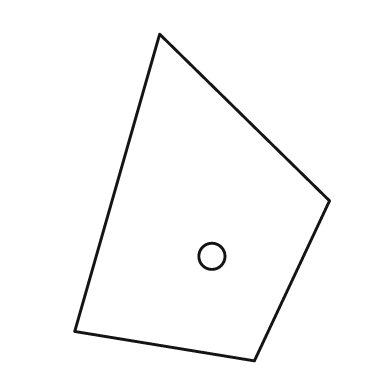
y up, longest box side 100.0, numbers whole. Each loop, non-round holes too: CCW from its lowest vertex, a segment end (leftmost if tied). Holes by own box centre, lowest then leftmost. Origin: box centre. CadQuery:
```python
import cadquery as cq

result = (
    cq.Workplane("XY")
    .moveTo(16.0, -50.0)
    .lineTo(39.0, -1.0)
    .lineTo(-13.0, 50.0)
    .lineTo(-39.0, -41.0)
    .close()
    .moveTo(3.0, -18.0)
    .circle(4.0)
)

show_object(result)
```